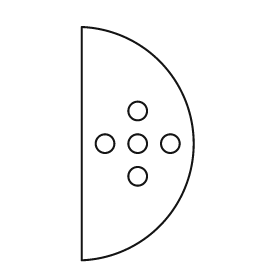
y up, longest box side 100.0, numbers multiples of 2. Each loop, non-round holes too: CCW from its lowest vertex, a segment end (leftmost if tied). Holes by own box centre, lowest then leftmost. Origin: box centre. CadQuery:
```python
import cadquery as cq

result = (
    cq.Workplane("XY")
    .moveTo(-24.0, -50.0)
    .threePointArc((24.0, 0.0), (-24.0, 50.0))
    .close()
    .moveTo(0.0, -14.0)
    .circle(4.0)
    .moveTo(-14.0, 0.0)
    .circle(4.0)
    .moveTo(0.0, 0.0)
    .circle(4.0)
    .moveTo(14.0, 0.0)
    .circle(4.0)
    .moveTo(0.0, 14.0)
    .circle(4.0)
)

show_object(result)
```